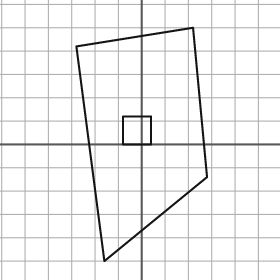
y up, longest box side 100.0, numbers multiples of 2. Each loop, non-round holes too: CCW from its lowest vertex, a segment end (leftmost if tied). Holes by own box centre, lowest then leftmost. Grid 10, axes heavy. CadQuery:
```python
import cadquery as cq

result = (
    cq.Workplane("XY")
    .moveTo(-16.0, -50.0)
    .lineTo(28.0, -14.0)
    .lineTo(22.0, 50.0)
    .lineTo(-28.0, 42.0)
    .close()
    .moveTo(-8.0, 0.0)
    .lineTo(4.0, 0.0)
    .lineTo(4.0, 12.0)
    .lineTo(-8.0, 12.0)
    .close()
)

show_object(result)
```